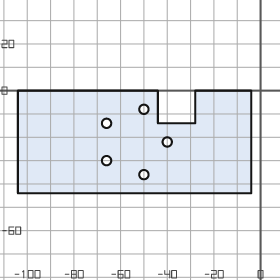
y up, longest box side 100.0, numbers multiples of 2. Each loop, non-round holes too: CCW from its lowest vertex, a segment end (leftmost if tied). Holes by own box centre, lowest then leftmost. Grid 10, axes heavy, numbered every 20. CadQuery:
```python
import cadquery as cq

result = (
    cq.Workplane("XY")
    .moveTo(-104.0, -44.0)
    .lineTo(-4.0, -44.0)
    .lineTo(-4.0, 0.0)
    .lineTo(-28.0, 0.0)
    .lineTo(-28.0, -14.0)
    .lineTo(-44.0, -14.0)
    .lineTo(-44.0, 0.0)
    .lineTo(-104.0, 0.0)
    .close()
    .moveTo(-50.0, -36.0)
    .circle(2.0)
    .moveTo(-66.0, -30.0)
    .circle(2.0)
    .moveTo(-40.0, -22.0)
    .circle(2.0)
    .moveTo(-66.0, -14.0)
    .circle(2.0)
    .moveTo(-50.0, -8.0)
    .circle(2.0)
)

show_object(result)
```